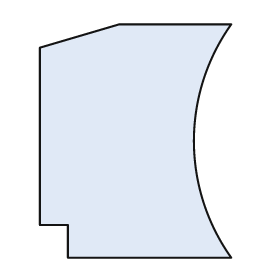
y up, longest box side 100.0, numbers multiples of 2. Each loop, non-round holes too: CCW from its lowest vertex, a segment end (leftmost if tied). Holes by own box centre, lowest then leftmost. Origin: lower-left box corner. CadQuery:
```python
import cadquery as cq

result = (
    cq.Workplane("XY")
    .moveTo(12.0, 0.0)
    .lineTo(82.0, 0.0)
    .threePointArc((66.0, 50.0), (82.0, 100.0))
    .lineTo(34.0, 100.0)
    .lineTo(0.0, 90.0)
    .lineTo(0.0, 14.0)
    .lineTo(12.0, 14.0)
    .close()
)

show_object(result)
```